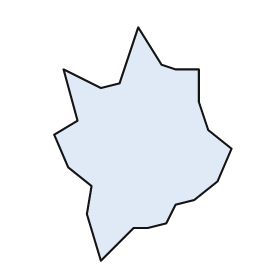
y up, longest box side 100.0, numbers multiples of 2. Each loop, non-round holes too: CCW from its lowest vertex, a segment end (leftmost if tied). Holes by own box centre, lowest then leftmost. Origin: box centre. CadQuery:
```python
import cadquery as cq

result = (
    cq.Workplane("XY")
    .moveTo(-18.0, -50.0)
    .lineTo(-4.0, -36.0)
    .lineTo(2.0, -36.0)
    .lineTo(10.0, -34.0)
    .lineTo(14.0, -26.0)
    .lineTo(22.0, -24.0)
    .lineTo(32.0, -16.0)
    .lineTo(38.0, -2.0)
    .lineTo(28.0, 6.0)
    .lineTo(24.0, 18.0)
    .lineTo(24.0, 32.0)
    .lineTo(14.0, 32.0)
    .lineTo(8.0, 34.0)
    .lineTo(-2.0, 50.0)
    .lineTo(-10.0, 26.0)
    .lineTo(-18.0, 24.0)
    .lineTo(-34.0, 32.0)
    .lineTo(-28.0, 10.0)
    .lineTo(-38.0, 4.0)
    .lineTo(-32.0, -10.0)
    .lineTo(-22.0, -18.0)
    .lineTo(-24.0, -30.0)
    .close()
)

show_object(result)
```